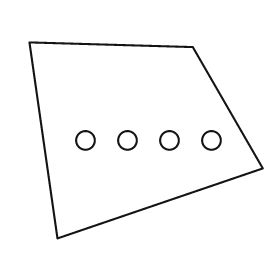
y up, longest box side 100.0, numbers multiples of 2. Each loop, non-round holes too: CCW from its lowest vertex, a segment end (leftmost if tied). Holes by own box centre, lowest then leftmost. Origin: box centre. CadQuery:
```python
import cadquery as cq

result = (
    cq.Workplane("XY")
    .moveTo(-38.0, -42.0)
    .lineTo(50.0, -12.0)
    .lineTo(20.0, 40.0)
    .lineTo(-50.0, 42.0)
    .close()
    .moveTo(-26.0, 0.0)
    .circle(4.0)
    .moveTo(-8.0, 0.0)
    .circle(4.0)
    .moveTo(10.0, 0.0)
    .circle(4.0)
    .moveTo(28.0, 0.0)
    .circle(4.0)
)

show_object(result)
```